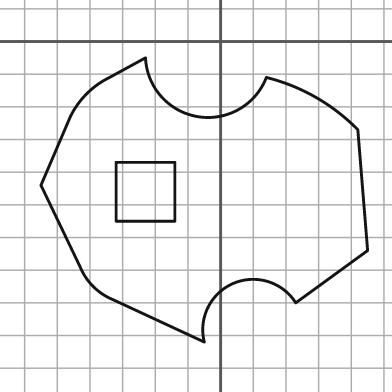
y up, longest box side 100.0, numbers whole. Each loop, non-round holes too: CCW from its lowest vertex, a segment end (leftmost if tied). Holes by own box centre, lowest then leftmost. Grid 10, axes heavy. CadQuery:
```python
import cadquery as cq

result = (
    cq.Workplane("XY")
    .moveTo(-5.0, -92.0)
    .threePointArc((4.0, -74.0), (23.0, -80.0))
    .lineTo(45.0, -64.0)
    .lineTo(42.0, -27.0)
    .threePointArc((29.0, -17.0), (14.0, -11.0))
    .threePointArc((-7.0, -23.0), (-23.0, -5.0))
    .lineTo(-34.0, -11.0)
    .threePointArc((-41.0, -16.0), (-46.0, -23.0))
    .lineTo(-55.0, -44.0)
    .lineTo(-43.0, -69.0)
    .threePointArc((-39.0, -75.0), (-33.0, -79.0))
    .close()
    .moveTo(-32.0, -55.0)
    .lineTo(-14.0, -55.0)
    .lineTo(-14.0, -37.0)
    .lineTo(-32.0, -37.0)
    .close()
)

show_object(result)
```